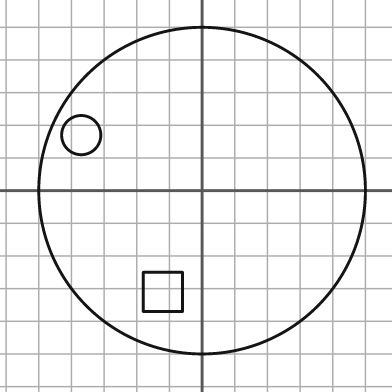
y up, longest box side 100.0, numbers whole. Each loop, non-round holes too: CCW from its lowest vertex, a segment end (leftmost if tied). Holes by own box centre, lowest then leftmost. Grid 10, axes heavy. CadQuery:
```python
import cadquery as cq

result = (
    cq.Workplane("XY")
    .moveTo(0.0, 0.0)
    .circle(50.0)
    .moveTo(-18.0, -37.0)
    .lineTo(-6.0, -37.0)
    .lineTo(-6.0, -25.0)
    .lineTo(-18.0, -25.0)
    .close()
    .moveTo(-37.0, 17.0)
    .circle(6.0)
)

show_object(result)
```